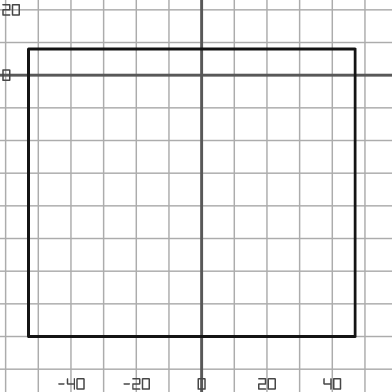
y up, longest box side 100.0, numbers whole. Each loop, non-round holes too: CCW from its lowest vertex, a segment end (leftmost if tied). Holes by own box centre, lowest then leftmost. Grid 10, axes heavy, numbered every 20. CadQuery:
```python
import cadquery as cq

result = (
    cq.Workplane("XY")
    .moveTo(-53.0, -80.0)
    .lineTo(47.0, -80.0)
    .lineTo(47.0, 8.0)
    .lineTo(-53.0, 8.0)
    .close()
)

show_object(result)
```